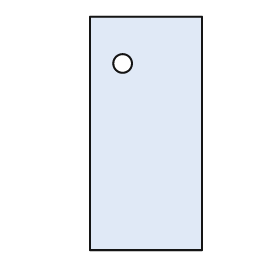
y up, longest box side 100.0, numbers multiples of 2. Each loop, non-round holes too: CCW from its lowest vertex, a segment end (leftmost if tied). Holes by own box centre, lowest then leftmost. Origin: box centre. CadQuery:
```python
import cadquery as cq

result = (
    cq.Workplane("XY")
    .moveTo(-24.0, -50.0)
    .lineTo(24.0, -50.0)
    .lineTo(24.0, 50.0)
    .lineTo(-24.0, 50.0)
    .close()
    .moveTo(-10.0, 30.0)
    .circle(4.0)
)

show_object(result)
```